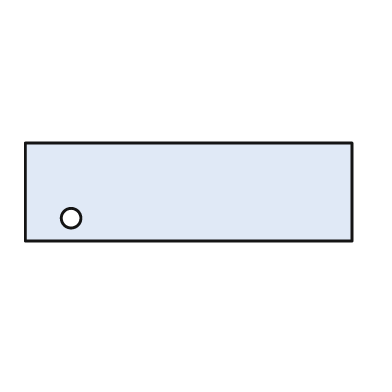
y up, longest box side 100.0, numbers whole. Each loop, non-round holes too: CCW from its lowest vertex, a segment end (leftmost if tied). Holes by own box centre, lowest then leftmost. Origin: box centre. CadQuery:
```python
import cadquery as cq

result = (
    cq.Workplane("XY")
    .moveTo(-50.0, -15.0)
    .lineTo(50.0, -15.0)
    .lineTo(50.0, 15.0)
    .lineTo(-50.0, 15.0)
    .close()
    .moveTo(-36.0, -8.0)
    .circle(3.0)
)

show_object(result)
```